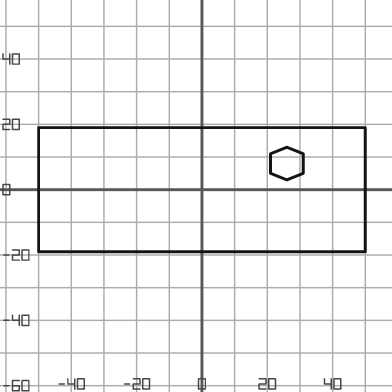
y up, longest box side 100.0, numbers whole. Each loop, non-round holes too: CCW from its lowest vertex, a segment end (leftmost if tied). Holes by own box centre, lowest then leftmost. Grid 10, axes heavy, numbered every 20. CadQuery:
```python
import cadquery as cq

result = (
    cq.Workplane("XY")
    .moveTo(-50.0, -19.0)
    .lineTo(50.0, -19.0)
    .lineTo(50.0, 19.0)
    .lineTo(-50.0, 19.0)
    .close()
    .moveTo(26.0, 3.0)
    .lineTo(31.0, 5.0)
    .lineTo(31.0, 11.0)
    .lineTo(26.0, 13.0)
    .lineTo(21.0, 11.0)
    .lineTo(21.0, 5.0)
    .close()
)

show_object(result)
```